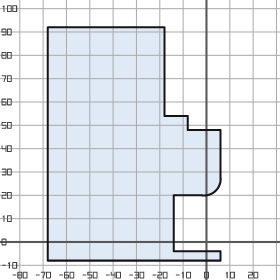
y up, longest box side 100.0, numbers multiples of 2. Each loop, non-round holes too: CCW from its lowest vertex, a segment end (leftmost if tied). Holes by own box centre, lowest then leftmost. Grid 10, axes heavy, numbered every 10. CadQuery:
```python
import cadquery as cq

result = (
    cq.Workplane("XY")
    .moveTo(-68.0, -8.0)
    .lineTo(6.0, -8.0)
    .lineTo(6.0, -4.0)
    .lineTo(-14.0, -4.0)
    .lineTo(-14.0, 20.0)
    .lineTo(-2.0, 20.0)
    .threePointArc((4.0, 22.0), (6.0, 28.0))
    .lineTo(6.0, 48.0)
    .lineTo(-8.0, 48.0)
    .lineTo(-8.0, 54.0)
    .lineTo(-18.0, 54.0)
    .lineTo(-18.0, 92.0)
    .lineTo(-68.0, 92.0)
    .close()
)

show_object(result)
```